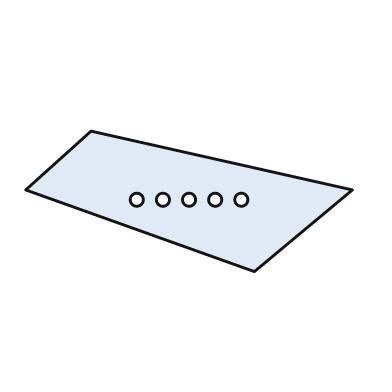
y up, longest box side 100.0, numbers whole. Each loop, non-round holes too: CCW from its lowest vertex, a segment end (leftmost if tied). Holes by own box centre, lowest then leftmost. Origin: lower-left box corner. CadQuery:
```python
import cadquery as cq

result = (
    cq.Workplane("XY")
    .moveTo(70.0, 0.0)
    .lineTo(100.0, 25.0)
    .lineTo(20.0, 43.0)
    .lineTo(0.0, 25.0)
    .close()
    .moveTo(34.0, 22.0)
    .circle(2.0)
    .moveTo(42.0, 22.0)
    .circle(2.0)
    .moveTo(50.0, 22.0)
    .circle(2.0)
    .moveTo(58.0, 22.0)
    .circle(2.0)
    .moveTo(66.0, 22.0)
    .circle(2.0)
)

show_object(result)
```